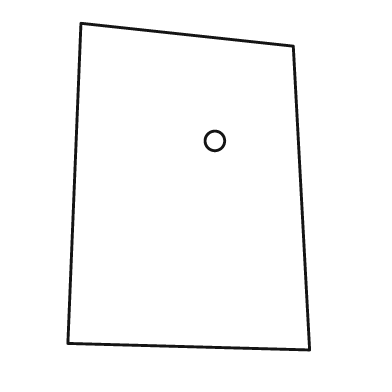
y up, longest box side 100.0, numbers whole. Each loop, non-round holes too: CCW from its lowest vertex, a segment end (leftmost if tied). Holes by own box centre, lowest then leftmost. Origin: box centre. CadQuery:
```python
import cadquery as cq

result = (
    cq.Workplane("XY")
    .moveTo(37.0, -50.0)
    .lineTo(32.0, 43.0)
    .lineTo(-33.0, 50.0)
    .lineTo(-37.0, -48.0)
    .close()
    .moveTo(8.0, 14.0)
    .circle(3.0)
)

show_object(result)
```